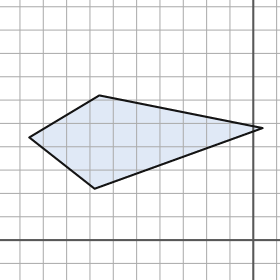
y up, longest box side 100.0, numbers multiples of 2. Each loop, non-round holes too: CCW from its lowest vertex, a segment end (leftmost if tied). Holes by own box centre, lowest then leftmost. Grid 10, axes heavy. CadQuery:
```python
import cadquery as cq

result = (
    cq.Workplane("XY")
    .moveTo(-68.0, 22.0)
    .lineTo(4.0, 48.0)
    .lineTo(-66.0, 62.0)
    .lineTo(-96.0, 44.0)
    .close()
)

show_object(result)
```